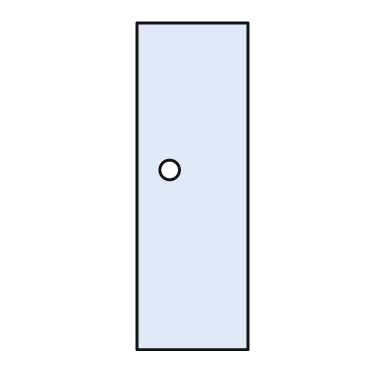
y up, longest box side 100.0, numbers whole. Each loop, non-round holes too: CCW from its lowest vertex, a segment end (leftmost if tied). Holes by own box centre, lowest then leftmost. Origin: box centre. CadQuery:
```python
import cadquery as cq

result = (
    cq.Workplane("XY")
    .moveTo(-17.0, -50.0)
    .lineTo(17.0, -50.0)
    .lineTo(17.0, 50.0)
    .lineTo(-17.0, 50.0)
    .close()
    .moveTo(-7.0, 5.0)
    .circle(3.0)
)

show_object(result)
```